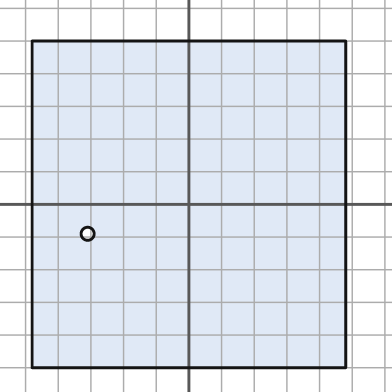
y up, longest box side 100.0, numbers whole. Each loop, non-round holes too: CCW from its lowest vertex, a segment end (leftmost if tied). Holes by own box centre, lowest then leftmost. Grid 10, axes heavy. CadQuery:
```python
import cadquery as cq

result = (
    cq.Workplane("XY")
    .moveTo(-48.0, -50.0)
    .lineTo(48.0, -50.0)
    .lineTo(48.0, 50.0)
    .lineTo(-48.0, 50.0)
    .close()
    .moveTo(-31.0, -9.0)
    .circle(2.0)
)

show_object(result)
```